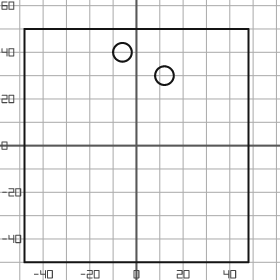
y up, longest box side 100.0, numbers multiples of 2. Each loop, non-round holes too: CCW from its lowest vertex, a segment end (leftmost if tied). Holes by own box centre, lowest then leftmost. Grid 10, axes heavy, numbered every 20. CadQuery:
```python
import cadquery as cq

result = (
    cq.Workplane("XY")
    .moveTo(-48.0, -50.0)
    .lineTo(48.0, -50.0)
    .lineTo(48.0, 50.0)
    .lineTo(-48.0, 50.0)
    .close()
    .moveTo(12.0, 30.0)
    .circle(4.0)
    .moveTo(-6.0, 40.0)
    .circle(4.0)
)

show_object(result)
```